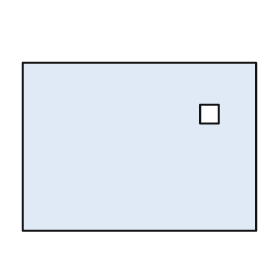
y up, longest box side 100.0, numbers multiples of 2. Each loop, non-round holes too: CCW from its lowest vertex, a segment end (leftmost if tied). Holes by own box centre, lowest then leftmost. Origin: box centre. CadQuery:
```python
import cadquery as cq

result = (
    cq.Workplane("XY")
    .moveTo(-50.0, -36.0)
    .lineTo(50.0, -36.0)
    .lineTo(50.0, 36.0)
    .lineTo(-50.0, 36.0)
    .close()
    .moveTo(26.0, 10.0)
    .lineTo(34.0, 10.0)
    .lineTo(34.0, 18.0)
    .lineTo(26.0, 18.0)
    .close()
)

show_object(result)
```